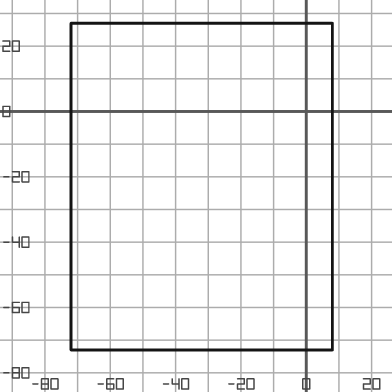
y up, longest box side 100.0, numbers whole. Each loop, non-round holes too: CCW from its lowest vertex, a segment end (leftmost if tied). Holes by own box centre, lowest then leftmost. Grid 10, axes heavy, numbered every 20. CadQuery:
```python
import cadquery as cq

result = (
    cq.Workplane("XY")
    .moveTo(-72.0, -73.0)
    .lineTo(8.0, -73.0)
    .lineTo(8.0, 27.0)
    .lineTo(-72.0, 27.0)
    .close()
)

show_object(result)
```